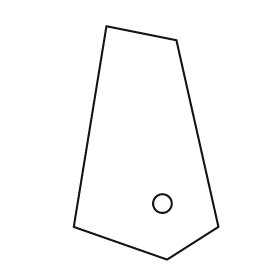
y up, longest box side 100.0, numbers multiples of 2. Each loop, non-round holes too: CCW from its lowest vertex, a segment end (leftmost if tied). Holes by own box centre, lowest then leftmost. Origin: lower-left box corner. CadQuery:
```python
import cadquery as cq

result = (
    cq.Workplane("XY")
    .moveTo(40.0, 0.0)
    .lineTo(62.0, 14.0)
    .lineTo(44.0, 94.0)
    .lineTo(14.0, 100.0)
    .lineTo(0.0, 14.0)
    .close()
    .moveTo(38.0, 24.0)
    .circle(4.0)
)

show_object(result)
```